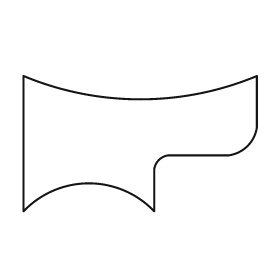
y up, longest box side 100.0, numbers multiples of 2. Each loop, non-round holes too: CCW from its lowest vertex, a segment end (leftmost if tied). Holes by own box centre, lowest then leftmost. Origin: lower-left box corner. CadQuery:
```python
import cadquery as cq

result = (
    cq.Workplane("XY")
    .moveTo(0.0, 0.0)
    .threePointArc((28.0, 12.0), (56.0, 0.0))
    .lineTo(56.0, 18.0)
    .threePointArc((58.0, 22.0), (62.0, 24.0))
    .lineTo(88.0, 24.0)
    .threePointArc((96.0, 28.0), (100.0, 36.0))
    .lineTo(100.0, 58.0)
    .threePointArc((50.0, 48.0), (0.0, 58.0))
    .close()
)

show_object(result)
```